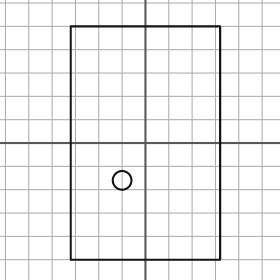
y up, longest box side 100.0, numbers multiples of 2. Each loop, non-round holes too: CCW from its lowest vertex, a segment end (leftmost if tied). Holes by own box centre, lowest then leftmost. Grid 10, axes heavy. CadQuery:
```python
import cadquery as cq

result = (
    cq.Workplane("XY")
    .moveTo(-32.0, -50.0)
    .lineTo(32.0, -50.0)
    .lineTo(32.0, 50.0)
    .lineTo(-32.0, 50.0)
    .close()
    .moveTo(-10.0, -16.0)
    .circle(4.0)
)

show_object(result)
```